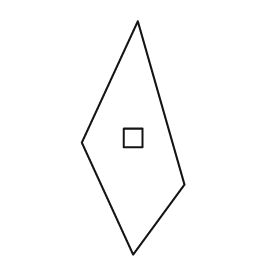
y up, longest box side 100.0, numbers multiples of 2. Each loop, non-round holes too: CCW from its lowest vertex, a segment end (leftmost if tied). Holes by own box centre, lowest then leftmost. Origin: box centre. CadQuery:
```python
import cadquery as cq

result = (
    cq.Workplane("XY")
    .moveTo(0.0, -50.0)
    .lineTo(22.0, -20.0)
    .lineTo(2.0, 50.0)
    .lineTo(-22.0, -2.0)
    .close()
    .moveTo(-4.0, -4.0)
    .lineTo(4.0, -4.0)
    .lineTo(4.0, 4.0)
    .lineTo(-4.0, 4.0)
    .close()
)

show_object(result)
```